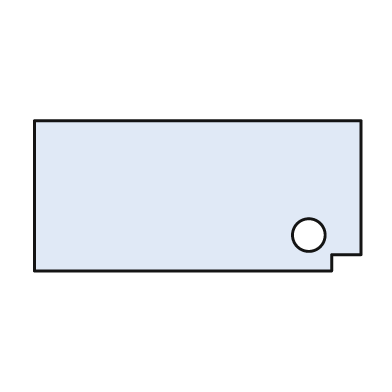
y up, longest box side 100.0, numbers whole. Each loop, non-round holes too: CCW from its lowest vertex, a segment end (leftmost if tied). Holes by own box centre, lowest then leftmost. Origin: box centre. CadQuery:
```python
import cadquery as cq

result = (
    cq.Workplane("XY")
    .moveTo(-50.0, -23.0)
    .lineTo(41.0, -23.0)
    .lineTo(41.0, -18.0)
    .lineTo(50.0, -18.0)
    .lineTo(50.0, 23.0)
    .lineTo(-50.0, 23.0)
    .close()
    .moveTo(34.0, -12.0)
    .circle(5.0)
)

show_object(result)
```